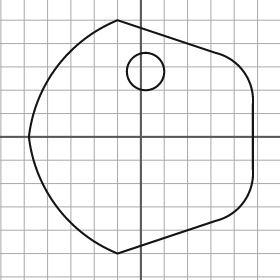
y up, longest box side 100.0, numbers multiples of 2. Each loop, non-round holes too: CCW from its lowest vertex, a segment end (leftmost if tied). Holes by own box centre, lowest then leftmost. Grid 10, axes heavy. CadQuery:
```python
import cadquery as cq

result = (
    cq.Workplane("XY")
    .moveTo(-10.0, -50.0)
    .lineTo(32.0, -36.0)
    .threePointArc((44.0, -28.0), (48.0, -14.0))
    .lineTo(48.0, 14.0)
    .threePointArc((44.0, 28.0), (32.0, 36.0))
    .lineTo(-10.0, 50.0)
    .threePointArc((-36.0, 30.0), (-48.0, 0.0))
    .threePointArc((-36.0, -30.0), (-10.0, -50.0))
    .close()
    .moveTo(2.0, 28.0)
    .circle(8.0)
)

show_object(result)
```